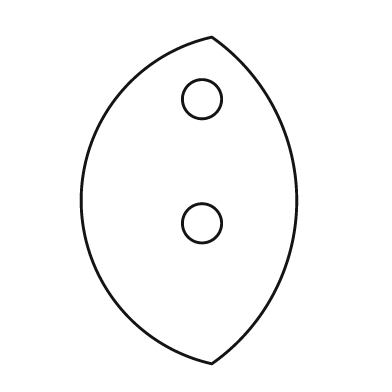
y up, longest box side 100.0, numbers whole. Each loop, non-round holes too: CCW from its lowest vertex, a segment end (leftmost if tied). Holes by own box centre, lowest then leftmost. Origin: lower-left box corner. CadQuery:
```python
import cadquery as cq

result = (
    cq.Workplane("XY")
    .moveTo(40.0, 0.0)
    .threePointArc((66.0, 50.0), (40.0, 100.0))
    .threePointArc((0.0, 50.0), (40.0, 0.0))
    .close()
    .moveTo(37.0, 43.0)
    .circle(6.0)
    .moveTo(37.0, 81.0)
    .circle(6.0)
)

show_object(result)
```